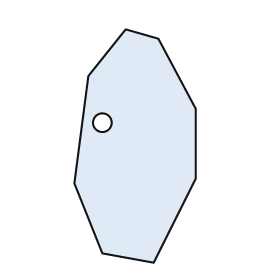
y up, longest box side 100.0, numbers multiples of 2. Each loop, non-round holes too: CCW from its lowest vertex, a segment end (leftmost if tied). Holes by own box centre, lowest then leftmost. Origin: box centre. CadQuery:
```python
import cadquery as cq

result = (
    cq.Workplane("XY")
    .moveTo(8.0, -50.0)
    .lineTo(26.0, -14.0)
    .lineTo(26.0, 16.0)
    .lineTo(10.0, 46.0)
    .lineTo(-4.0, 50.0)
    .lineTo(-20.0, 30.0)
    .lineTo(-26.0, -16.0)
    .lineTo(-14.0, -46.0)
    .close()
    .moveTo(-14.0, 10.0)
    .circle(4.0)
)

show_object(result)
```